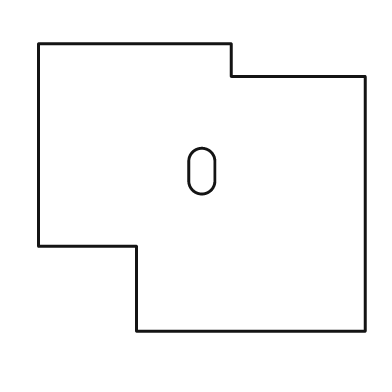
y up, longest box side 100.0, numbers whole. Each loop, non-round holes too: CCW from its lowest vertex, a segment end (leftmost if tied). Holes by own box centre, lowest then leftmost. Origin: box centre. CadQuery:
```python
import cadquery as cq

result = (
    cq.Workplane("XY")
    .moveTo(-20.0, -44.0)
    .lineTo(50.0, -44.0)
    .lineTo(50.0, 34.0)
    .lineTo(9.0, 34.0)
    .lineTo(9.0, 44.0)
    .lineTo(-50.0, 44.0)
    .lineTo(-50.0, -18.0)
    .lineTo(-20.0, -18.0)
    .close()
    .moveTo(-4.0, 2.0)
    .threePointArc((0.0, -2.0), (4.0, 2.0))
    .lineTo(4.0, 8.0)
    .threePointArc((0.0, 12.0), (-4.0, 8.0))
    .close()
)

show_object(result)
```